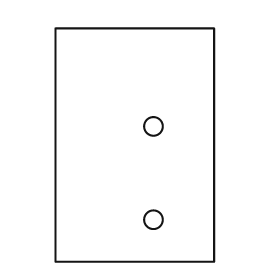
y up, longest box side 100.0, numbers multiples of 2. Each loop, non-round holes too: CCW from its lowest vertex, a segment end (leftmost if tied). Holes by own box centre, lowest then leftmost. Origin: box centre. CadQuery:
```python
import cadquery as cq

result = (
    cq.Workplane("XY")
    .moveTo(-34.0, -50.0)
    .lineTo(34.0, -50.0)
    .lineTo(34.0, 50.0)
    .lineTo(-34.0, 50.0)
    .close()
    .moveTo(8.0, -32.0)
    .circle(4.0)
    .moveTo(8.0, 8.0)
    .circle(4.0)
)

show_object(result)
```